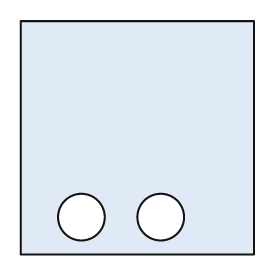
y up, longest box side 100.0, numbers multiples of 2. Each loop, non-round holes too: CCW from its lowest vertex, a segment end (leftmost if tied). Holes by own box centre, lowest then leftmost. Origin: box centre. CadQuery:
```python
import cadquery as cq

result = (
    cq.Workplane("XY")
    .moveTo(-50.0, -50.0)
    .lineTo(50.0, -50.0)
    .lineTo(50.0, 50.0)
    .lineTo(-50.0, 50.0)
    .close()
    .moveTo(-24.0, -34.0)
    .circle(10.0)
    .moveTo(10.0, -34.0)
    .circle(10.0)
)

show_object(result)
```